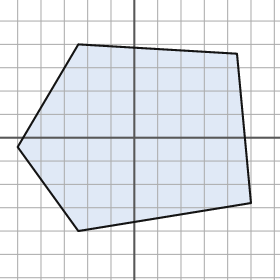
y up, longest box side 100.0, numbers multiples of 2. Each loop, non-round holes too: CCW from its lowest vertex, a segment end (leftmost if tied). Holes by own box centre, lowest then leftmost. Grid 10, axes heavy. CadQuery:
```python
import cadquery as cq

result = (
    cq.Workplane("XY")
    .moveTo(-24.0, -40.0)
    .lineTo(50.0, -28.0)
    .lineTo(44.0, 36.0)
    .lineTo(-24.0, 40.0)
    .lineTo(-50.0, -4.0)
    .close()
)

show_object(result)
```